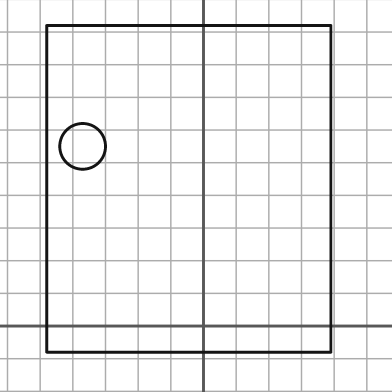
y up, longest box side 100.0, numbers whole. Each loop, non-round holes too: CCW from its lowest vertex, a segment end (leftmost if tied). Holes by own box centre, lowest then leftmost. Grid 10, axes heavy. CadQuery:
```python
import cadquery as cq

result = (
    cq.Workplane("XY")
    .moveTo(-48.0, -8.0)
    .lineTo(39.0, -8.0)
    .lineTo(39.0, 92.0)
    .lineTo(-48.0, 92.0)
    .close()
    .moveTo(-37.0, 55.0)
    .circle(7.0)
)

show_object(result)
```